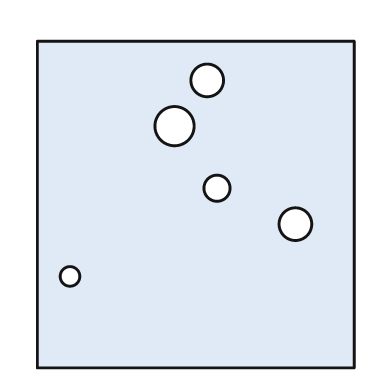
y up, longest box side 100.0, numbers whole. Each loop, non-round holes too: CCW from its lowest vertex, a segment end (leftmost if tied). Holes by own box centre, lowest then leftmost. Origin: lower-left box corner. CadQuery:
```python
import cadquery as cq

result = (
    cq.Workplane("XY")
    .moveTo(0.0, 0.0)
    .lineTo(97.0, 0.0)
    .lineTo(97.0, 100.0)
    .lineTo(0.0, 100.0)
    .close()
    .moveTo(10.0, 28.0)
    .circle(3.0)
    .moveTo(79.0, 44.0)
    .circle(5.0)
    .moveTo(55.0, 55.0)
    .circle(4.0)
    .moveTo(42.0, 74.0)
    .circle(6.0)
    .moveTo(52.0, 88.0)
    .circle(5.0)
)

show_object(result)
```